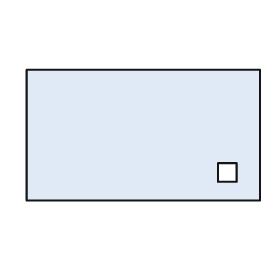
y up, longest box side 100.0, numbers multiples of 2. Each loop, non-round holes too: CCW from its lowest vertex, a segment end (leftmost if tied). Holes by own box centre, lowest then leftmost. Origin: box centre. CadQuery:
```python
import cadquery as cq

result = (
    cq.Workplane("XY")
    .moveTo(-50.0, -28.0)
    .lineTo(50.0, -28.0)
    .lineTo(50.0, 28.0)
    .lineTo(-50.0, 28.0)
    .close()
    .moveTo(32.0, -20.0)
    .lineTo(40.0, -20.0)
    .lineTo(40.0, -12.0)
    .lineTo(32.0, -12.0)
    .close()
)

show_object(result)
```